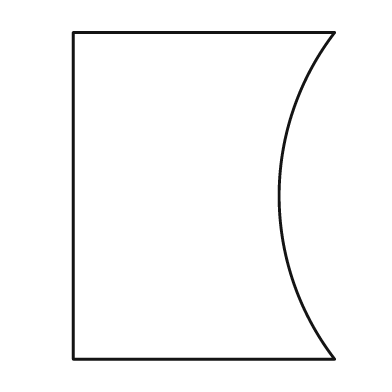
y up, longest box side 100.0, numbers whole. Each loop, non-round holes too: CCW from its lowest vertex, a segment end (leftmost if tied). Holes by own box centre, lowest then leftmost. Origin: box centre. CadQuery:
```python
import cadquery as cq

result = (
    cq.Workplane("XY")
    .moveTo(-40.0, -50.0)
    .lineTo(40.0, -50.0)
    .threePointArc((23.0, 0.0), (40.0, 50.0))
    .lineTo(-40.0, 50.0)
    .close()
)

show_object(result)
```